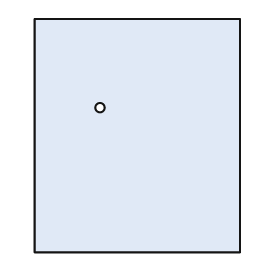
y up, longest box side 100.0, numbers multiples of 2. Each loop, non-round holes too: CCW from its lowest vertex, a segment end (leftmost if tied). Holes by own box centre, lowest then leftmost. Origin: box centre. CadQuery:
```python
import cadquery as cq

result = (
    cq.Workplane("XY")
    .moveTo(-44.0, -50.0)
    .lineTo(44.0, -50.0)
    .lineTo(44.0, 50.0)
    .lineTo(-44.0, 50.0)
    .close()
    .moveTo(-16.0, 12.0)
    .circle(2.0)
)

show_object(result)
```